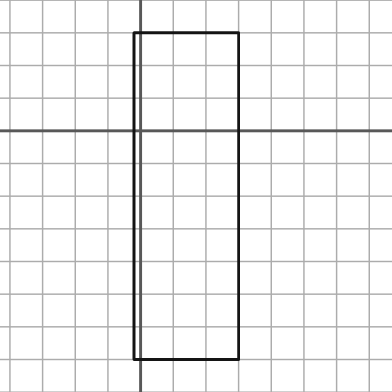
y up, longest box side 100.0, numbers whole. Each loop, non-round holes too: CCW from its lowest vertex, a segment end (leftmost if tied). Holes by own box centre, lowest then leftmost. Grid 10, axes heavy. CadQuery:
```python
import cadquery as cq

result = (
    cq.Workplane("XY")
    .moveTo(-2.0, -70.0)
    .lineTo(30.0, -70.0)
    .lineTo(30.0, 30.0)
    .lineTo(-2.0, 30.0)
    .close()
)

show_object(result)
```